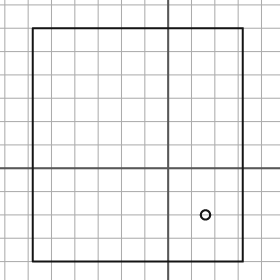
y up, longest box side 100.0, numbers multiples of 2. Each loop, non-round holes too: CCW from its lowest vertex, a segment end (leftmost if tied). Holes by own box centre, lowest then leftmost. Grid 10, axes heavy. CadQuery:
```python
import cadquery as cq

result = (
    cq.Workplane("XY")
    .moveTo(-58.0, -40.0)
    .lineTo(32.0, -40.0)
    .lineTo(32.0, 60.0)
    .lineTo(-58.0, 60.0)
    .close()
    .moveTo(16.0, -20.0)
    .circle(2.0)
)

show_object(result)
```